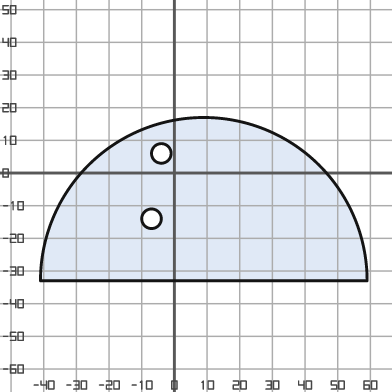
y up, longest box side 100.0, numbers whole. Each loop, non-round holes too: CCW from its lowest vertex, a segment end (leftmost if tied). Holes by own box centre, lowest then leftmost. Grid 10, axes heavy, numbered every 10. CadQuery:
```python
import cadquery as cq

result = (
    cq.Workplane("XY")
    .moveTo(-41.0, -33.0)
    .lineTo(59.0, -33.0)
    .threePointArc((9.0, 17.0), (-41.0, -33.0))
    .close()
    .moveTo(-7.0, -14.0)
    .circle(3.0)
    .moveTo(-4.0, 6.0)
    .circle(3.0)
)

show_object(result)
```